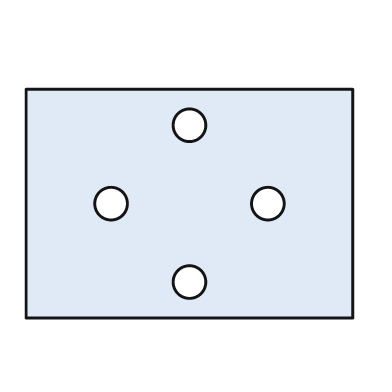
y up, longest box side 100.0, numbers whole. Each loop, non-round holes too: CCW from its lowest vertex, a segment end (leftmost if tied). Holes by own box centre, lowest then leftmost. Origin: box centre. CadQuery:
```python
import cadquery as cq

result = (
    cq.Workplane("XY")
    .moveTo(-50.0, -35.0)
    .lineTo(50.0, -35.0)
    .lineTo(50.0, 35.0)
    .lineTo(-50.0, 35.0)
    .close()
    .moveTo(0.0, -24.0)
    .circle(5.0)
    .moveTo(-24.0, 0.0)
    .circle(5.0)
    .moveTo(24.0, 0.0)
    .circle(5.0)
    .moveTo(0.0, 24.0)
    .circle(5.0)
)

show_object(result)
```